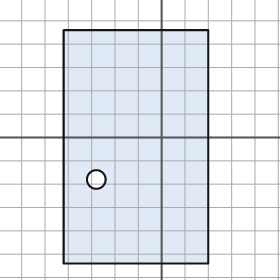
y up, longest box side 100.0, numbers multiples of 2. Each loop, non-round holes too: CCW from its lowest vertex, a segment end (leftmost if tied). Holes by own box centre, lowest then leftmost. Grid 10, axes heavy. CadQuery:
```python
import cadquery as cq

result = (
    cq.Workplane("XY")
    .moveTo(-42.0, -54.0)
    .lineTo(20.0, -54.0)
    .lineTo(20.0, 46.0)
    .lineTo(-42.0, 46.0)
    .close()
    .moveTo(-28.0, -18.0)
    .circle(4.0)
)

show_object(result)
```